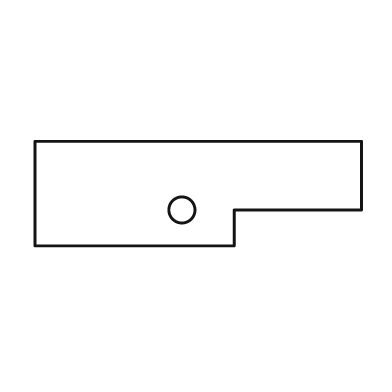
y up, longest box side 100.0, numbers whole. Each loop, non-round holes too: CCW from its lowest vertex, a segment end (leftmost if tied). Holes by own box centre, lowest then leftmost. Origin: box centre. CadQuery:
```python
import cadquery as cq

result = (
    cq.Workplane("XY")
    .moveTo(-50.0, -16.0)
    .lineTo(11.0, -16.0)
    .lineTo(11.0, -5.0)
    .lineTo(50.0, -5.0)
    .lineTo(50.0, 16.0)
    .lineTo(-50.0, 16.0)
    .close()
    .moveTo(-5.0, -5.0)
    .circle(4.0)
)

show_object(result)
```